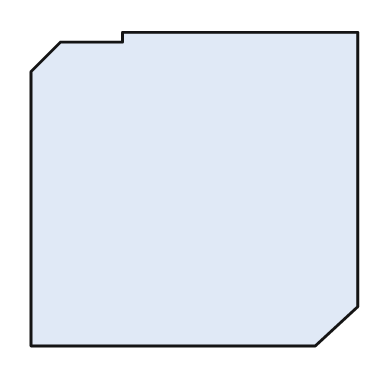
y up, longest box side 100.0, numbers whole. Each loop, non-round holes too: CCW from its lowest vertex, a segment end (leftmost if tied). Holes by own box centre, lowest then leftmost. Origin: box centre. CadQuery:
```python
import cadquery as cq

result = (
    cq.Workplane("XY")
    .moveTo(-50.0, -48.0)
    .lineTo(37.0, -48.0)
    .lineTo(50.0, -36.0)
    .lineTo(50.0, 48.0)
    .lineTo(-22.0, 48.0)
    .lineTo(-22.0, 45.0)
    .lineTo(-41.0, 45.0)
    .lineTo(-50.0, 36.0)
    .close()
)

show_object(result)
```